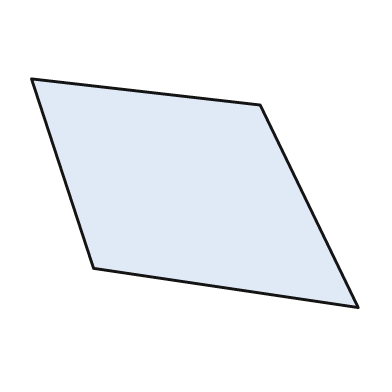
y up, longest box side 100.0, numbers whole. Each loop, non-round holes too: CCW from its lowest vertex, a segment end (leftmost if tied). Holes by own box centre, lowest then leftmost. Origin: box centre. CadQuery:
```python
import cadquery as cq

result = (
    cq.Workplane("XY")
    .moveTo(50.0, -35.0)
    .lineTo(20.0, 27.0)
    .lineTo(-50.0, 35.0)
    .lineTo(-31.0, -23.0)
    .close()
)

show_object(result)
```